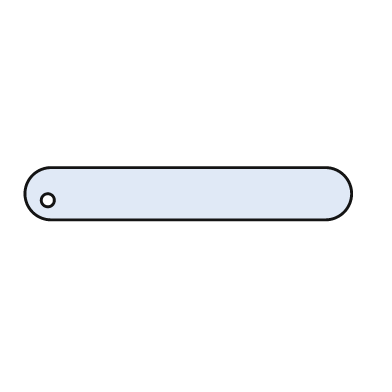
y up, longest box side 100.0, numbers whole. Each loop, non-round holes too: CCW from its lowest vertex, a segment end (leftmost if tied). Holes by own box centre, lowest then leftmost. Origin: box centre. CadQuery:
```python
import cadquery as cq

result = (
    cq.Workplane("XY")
    .moveTo(-42.0, -8.0)
    .lineTo(42.0, -8.0)
    .threePointArc((50.0, 0.0), (42.0, 8.0))
    .lineTo(-42.0, 8.0)
    .threePointArc((-50.0, 0.0), (-42.0, -8.0))
    .close()
    .moveTo(-43.0, -2.0)
    .circle(2.0)
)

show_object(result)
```